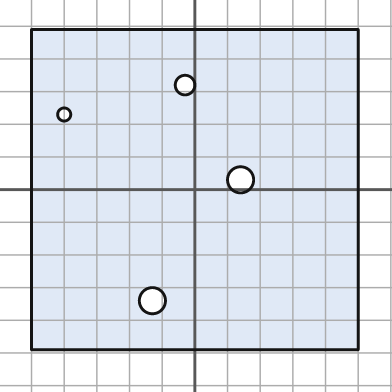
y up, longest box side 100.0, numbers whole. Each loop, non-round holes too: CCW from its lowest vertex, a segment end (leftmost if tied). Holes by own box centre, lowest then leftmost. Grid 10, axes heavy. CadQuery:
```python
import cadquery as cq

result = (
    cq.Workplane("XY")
    .moveTo(-50.0, -49.0)
    .lineTo(50.0, -49.0)
    .lineTo(50.0, 49.0)
    .lineTo(-50.0, 49.0)
    .close()
    .moveTo(-13.0, -34.0)
    .circle(4.0)
    .moveTo(14.0, 3.0)
    .circle(4.0)
    .moveTo(-40.0, 23.0)
    .circle(2.0)
    .moveTo(-3.0, 32.0)
    .circle(3.0)
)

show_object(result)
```